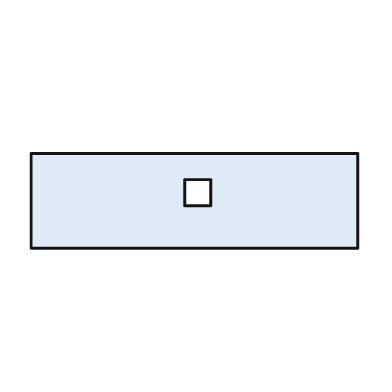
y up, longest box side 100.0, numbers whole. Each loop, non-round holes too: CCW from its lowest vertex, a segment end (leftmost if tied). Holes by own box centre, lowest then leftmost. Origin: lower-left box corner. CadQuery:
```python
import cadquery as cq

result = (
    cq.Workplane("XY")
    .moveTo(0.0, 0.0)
    .lineTo(100.0, 0.0)
    .lineTo(100.0, 29.0)
    .lineTo(0.0, 29.0)
    .close()
    .moveTo(47.0, 13.0)
    .lineTo(55.0, 13.0)
    .lineTo(55.0, 21.0)
    .lineTo(47.0, 21.0)
    .close()
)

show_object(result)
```